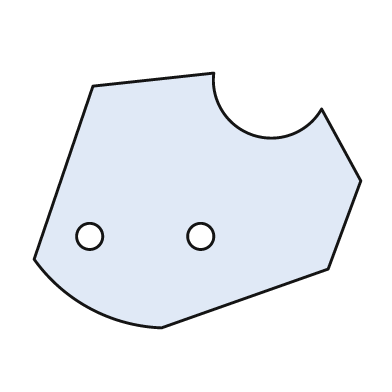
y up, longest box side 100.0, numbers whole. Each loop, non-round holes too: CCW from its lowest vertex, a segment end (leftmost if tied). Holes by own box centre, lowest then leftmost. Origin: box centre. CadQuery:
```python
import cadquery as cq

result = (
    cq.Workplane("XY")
    .moveTo(-11.0, -39.0)
    .lineTo(40.0, -21.0)
    .lineTo(50.0, 6.0)
    .lineTo(38.0, 28.0)
    .threePointArc((17.0, 20.0), (5.0, 39.0))
    .lineTo(-32.0, 35.0)
    .lineTo(-50.0, -18.0)
    .threePointArc((-33.0, -33.0), (-11.0, -39.0))
    .close()
    .moveTo(-33.0, -11.0)
    .circle(4.0)
    .moveTo(1.0, -11.0)
    .circle(4.0)
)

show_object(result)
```